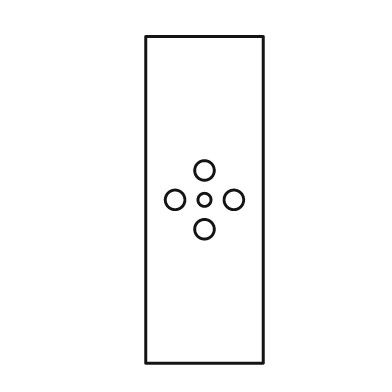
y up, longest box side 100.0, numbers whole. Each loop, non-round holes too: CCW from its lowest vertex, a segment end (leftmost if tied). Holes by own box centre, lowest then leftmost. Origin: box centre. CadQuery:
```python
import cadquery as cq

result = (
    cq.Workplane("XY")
    .moveTo(-18.0, -50.0)
    .lineTo(18.0, -50.0)
    .lineTo(18.0, 50.0)
    .lineTo(-18.0, 50.0)
    .close()
    .moveTo(0.0, -9.0)
    .circle(3.0)
    .moveTo(-9.0, 0.0)
    .circle(3.0)
    .moveTo(0.0, 0.0)
    .circle(2.0)
    .moveTo(9.0, 0.0)
    .circle(3.0)
    .moveTo(0.0, 9.0)
    .circle(3.0)
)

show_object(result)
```